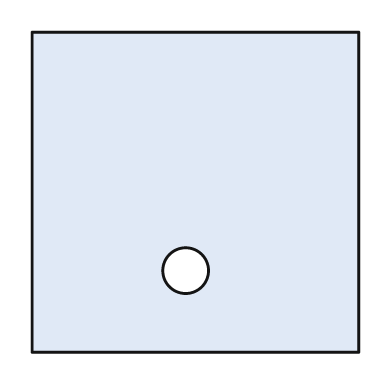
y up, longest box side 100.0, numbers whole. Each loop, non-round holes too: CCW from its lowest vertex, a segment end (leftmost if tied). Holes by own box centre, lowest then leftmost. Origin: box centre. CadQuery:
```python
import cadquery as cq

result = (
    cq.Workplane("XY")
    .moveTo(-50.0, -49.0)
    .lineTo(50.0, -49.0)
    .lineTo(50.0, 49.0)
    .lineTo(-50.0, 49.0)
    .close()
    .moveTo(-3.0, -24.0)
    .circle(7.0)
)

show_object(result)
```